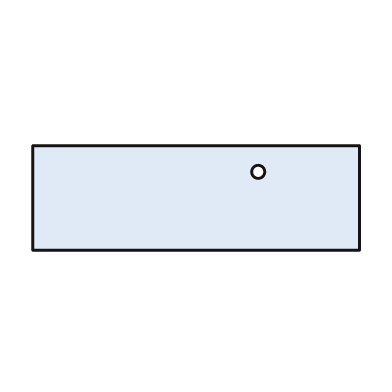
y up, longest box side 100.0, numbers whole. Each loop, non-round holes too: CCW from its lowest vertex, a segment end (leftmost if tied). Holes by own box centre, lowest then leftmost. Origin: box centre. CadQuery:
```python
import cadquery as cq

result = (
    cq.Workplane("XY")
    .moveTo(-50.0, -16.0)
    .lineTo(50.0, -16.0)
    .lineTo(50.0, 16.0)
    .lineTo(-50.0, 16.0)
    .close()
    .moveTo(19.0, 8.0)
    .circle(2.0)
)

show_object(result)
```